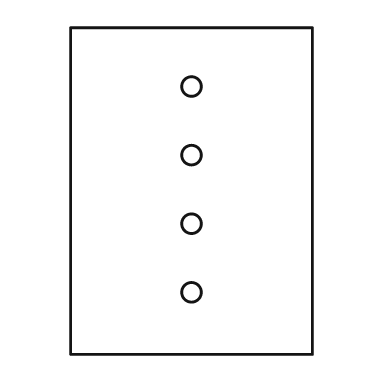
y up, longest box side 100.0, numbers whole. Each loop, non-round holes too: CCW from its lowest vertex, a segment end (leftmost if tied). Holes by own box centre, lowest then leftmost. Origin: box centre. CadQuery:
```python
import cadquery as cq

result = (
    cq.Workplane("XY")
    .moveTo(-37.0, -50.0)
    .lineTo(37.0, -50.0)
    .lineTo(37.0, 50.0)
    .lineTo(-37.0, 50.0)
    .close()
    .moveTo(0.0, -31.0)
    .circle(3.0)
    .moveTo(0.0, -10.0)
    .circle(3.0)
    .moveTo(0.0, 11.0)
    .circle(3.0)
    .moveTo(0.0, 32.0)
    .circle(3.0)
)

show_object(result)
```